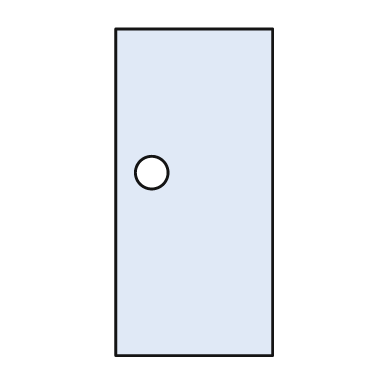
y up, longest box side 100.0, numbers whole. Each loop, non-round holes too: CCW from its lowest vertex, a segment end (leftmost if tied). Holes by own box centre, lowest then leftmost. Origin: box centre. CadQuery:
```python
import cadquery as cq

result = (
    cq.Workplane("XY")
    .moveTo(-24.0, -50.0)
    .lineTo(24.0, -50.0)
    .lineTo(24.0, 50.0)
    .lineTo(-24.0, 50.0)
    .close()
    .moveTo(-13.0, 6.0)
    .circle(5.0)
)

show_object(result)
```